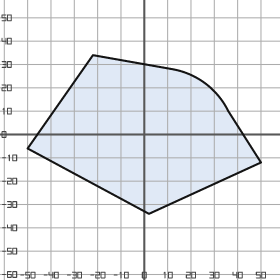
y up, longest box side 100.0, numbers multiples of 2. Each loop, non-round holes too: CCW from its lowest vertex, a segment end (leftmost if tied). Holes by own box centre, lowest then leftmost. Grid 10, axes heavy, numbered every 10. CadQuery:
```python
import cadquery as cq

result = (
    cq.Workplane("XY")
    .moveTo(2.0, -34.0)
    .lineTo(50.0, -12.0)
    .lineTo(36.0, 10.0)
    .threePointArc((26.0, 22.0), (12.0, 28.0))
    .lineTo(-22.0, 34.0)
    .lineTo(-50.0, -6.0)
    .close()
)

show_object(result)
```